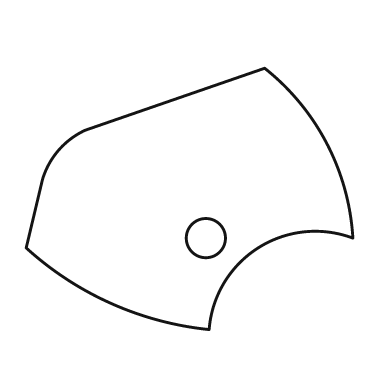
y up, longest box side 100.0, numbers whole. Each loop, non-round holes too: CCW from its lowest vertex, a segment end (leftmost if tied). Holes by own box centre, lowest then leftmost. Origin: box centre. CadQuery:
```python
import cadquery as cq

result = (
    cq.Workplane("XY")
    .moveTo(6.0, -40.0)
    .threePointArc((21.0, -15.0), (50.0, -12.0))
    .threePointArc((42.0, 17.0), (23.0, 40.0))
    .lineTo(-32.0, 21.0)
    .threePointArc((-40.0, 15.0), (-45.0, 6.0))
    .lineTo(-50.0, -15.0)
    .threePointArc((-24.0, -32.0), (6.0, -40.0))
    .close()
    .moveTo(5.0, -12.0)
    .circle(6.0)
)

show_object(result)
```